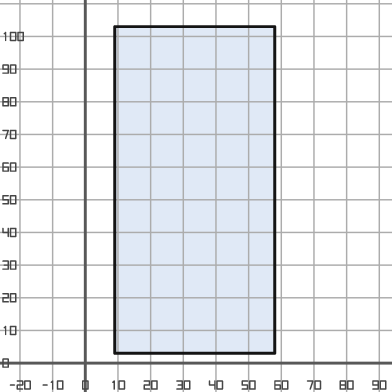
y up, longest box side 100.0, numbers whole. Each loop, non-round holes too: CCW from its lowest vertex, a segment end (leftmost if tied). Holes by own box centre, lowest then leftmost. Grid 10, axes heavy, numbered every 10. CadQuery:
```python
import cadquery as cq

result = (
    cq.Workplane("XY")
    .moveTo(9.0, 3.0)
    .lineTo(58.0, 3.0)
    .lineTo(58.0, 103.0)
    .lineTo(9.0, 103.0)
    .close()
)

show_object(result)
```